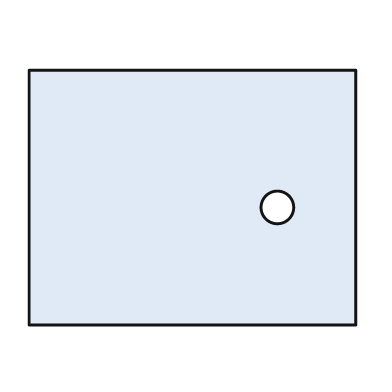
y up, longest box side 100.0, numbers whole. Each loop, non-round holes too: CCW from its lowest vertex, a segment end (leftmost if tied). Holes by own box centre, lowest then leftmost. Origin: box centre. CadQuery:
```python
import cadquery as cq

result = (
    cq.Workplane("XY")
    .moveTo(-50.0, -39.0)
    .lineTo(50.0, -39.0)
    .lineTo(50.0, 39.0)
    .lineTo(-50.0, 39.0)
    .close()
    .moveTo(26.0, -3.0)
    .circle(5.0)
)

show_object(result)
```